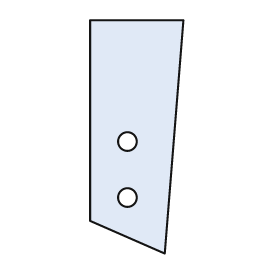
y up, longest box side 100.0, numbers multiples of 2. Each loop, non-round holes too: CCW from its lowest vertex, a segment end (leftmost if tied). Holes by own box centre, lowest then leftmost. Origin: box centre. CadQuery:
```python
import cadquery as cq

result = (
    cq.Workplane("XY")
    .moveTo(12.0, -50.0)
    .lineTo(20.0, 50.0)
    .lineTo(-20.0, 50.0)
    .lineTo(-20.0, -36.0)
    .close()
    .moveTo(-4.0, -26.0)
    .circle(4.0)
    .moveTo(-4.0, -2.0)
    .circle(4.0)
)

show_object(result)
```